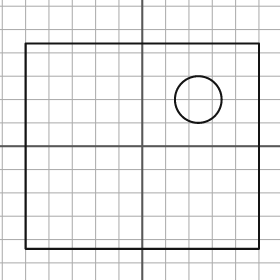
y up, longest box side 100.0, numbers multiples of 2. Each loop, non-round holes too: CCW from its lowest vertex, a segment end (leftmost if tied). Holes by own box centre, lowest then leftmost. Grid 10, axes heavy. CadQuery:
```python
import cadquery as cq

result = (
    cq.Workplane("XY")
    .moveTo(-50.0, -44.0)
    .lineTo(50.0, -44.0)
    .lineTo(50.0, 44.0)
    .lineTo(-50.0, 44.0)
    .close()
    .moveTo(24.0, 20.0)
    .circle(10.0)
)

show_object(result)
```